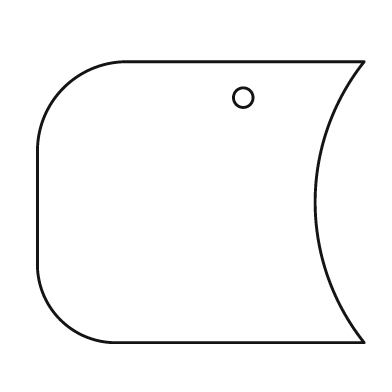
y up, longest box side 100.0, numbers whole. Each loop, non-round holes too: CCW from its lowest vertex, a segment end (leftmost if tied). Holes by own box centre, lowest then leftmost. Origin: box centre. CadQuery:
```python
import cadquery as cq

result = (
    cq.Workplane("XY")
    .moveTo(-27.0, -43.0)
    .lineTo(50.0, -43.0)
    .threePointArc((35.0, 0.0), (50.0, 43.0))
    .lineTo(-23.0, 43.0)
    .threePointArc((-42.0, 35.0), (-50.0, 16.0))
    .lineTo(-50.0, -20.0)
    .threePointArc((-43.0, -36.0), (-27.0, -43.0))
    .close()
    .moveTo(13.0, 32.0)
    .circle(3.0)
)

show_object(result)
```